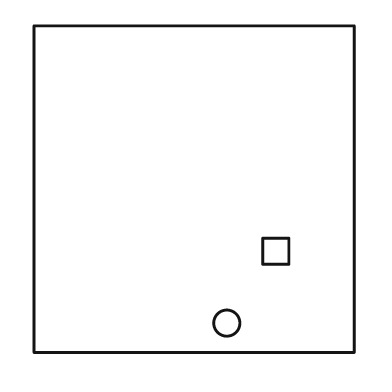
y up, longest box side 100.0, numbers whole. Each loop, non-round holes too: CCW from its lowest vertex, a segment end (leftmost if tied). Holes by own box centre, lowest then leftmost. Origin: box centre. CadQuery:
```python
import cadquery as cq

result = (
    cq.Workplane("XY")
    .moveTo(-49.0, -50.0)
    .lineTo(49.0, -50.0)
    .lineTo(49.0, 50.0)
    .lineTo(-49.0, 50.0)
    .close()
    .moveTo(10.0, -41.0)
    .circle(4.0)
    .moveTo(21.0, -23.0)
    .lineTo(29.0, -23.0)
    .lineTo(29.0, -15.0)
    .lineTo(21.0, -15.0)
    .close()
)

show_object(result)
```